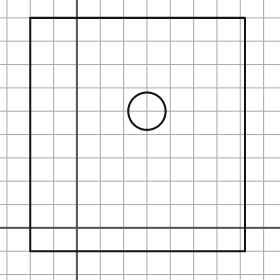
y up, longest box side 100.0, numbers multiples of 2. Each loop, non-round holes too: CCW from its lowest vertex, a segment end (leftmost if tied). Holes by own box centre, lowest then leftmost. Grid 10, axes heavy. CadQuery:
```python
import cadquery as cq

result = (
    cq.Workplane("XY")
    .moveTo(-20.0, -10.0)
    .lineTo(72.0, -10.0)
    .lineTo(72.0, 90.0)
    .lineTo(-20.0, 90.0)
    .close()
    .moveTo(30.0, 50.0)
    .circle(8.0)
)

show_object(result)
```